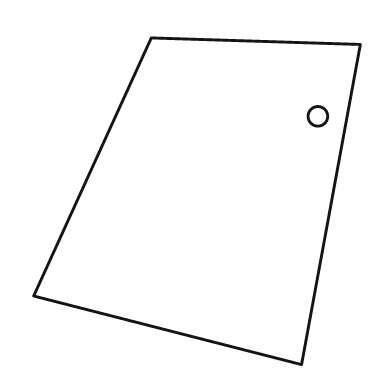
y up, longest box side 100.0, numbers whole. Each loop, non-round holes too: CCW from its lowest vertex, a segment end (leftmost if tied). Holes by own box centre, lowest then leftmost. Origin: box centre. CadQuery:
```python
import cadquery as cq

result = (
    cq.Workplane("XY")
    .moveTo(32.0, -50.0)
    .lineTo(50.0, 48.0)
    .lineTo(-14.0, 50.0)
    .lineTo(-50.0, -29.0)
    .close()
    .moveTo(37.0, 26.0)
    .circle(3.0)
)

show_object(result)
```